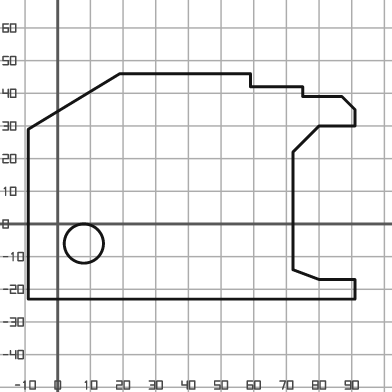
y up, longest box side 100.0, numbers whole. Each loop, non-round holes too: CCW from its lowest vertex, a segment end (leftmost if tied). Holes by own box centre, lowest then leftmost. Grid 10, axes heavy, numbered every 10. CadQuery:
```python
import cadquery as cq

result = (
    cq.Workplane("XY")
    .moveTo(-9.0, -23.0)
    .lineTo(91.0, -23.0)
    .lineTo(91.0, -17.0)
    .lineTo(80.0, -17.0)
    .lineTo(72.0, -14.0)
    .lineTo(72.0, 22.0)
    .lineTo(80.0, 30.0)
    .lineTo(91.0, 30.0)
    .lineTo(91.0, 35.0)
    .lineTo(87.0, 39.0)
    .lineTo(75.0, 39.0)
    .lineTo(75.0, 42.0)
    .lineTo(59.0, 42.0)
    .lineTo(59.0, 46.0)
    .lineTo(19.0, 46.0)
    .lineTo(-9.0, 29.0)
    .close()
    .moveTo(8.0, -6.0)
    .circle(6.0)
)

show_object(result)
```